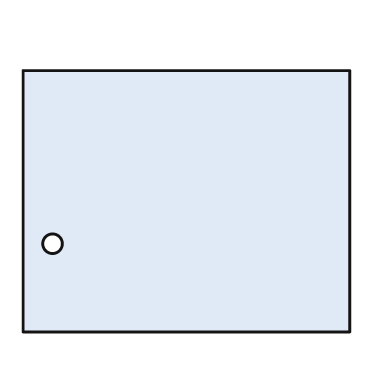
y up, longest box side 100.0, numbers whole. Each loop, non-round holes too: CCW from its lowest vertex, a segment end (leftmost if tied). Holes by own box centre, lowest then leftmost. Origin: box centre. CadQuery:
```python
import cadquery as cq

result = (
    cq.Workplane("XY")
    .moveTo(-50.0, -40.0)
    .lineTo(50.0, -40.0)
    .lineTo(50.0, 40.0)
    .lineTo(-50.0, 40.0)
    .close()
    .moveTo(-41.0, -13.0)
    .circle(3.0)
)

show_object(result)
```